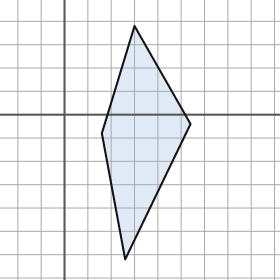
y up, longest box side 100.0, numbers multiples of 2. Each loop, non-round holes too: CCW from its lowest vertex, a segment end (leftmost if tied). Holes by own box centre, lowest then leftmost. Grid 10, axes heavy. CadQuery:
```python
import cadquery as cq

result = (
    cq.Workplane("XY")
    .moveTo(26.0, -62.0)
    .lineTo(54.0, -4.0)
    .lineTo(30.0, 38.0)
    .lineTo(16.0, -8.0)
    .close()
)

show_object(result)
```